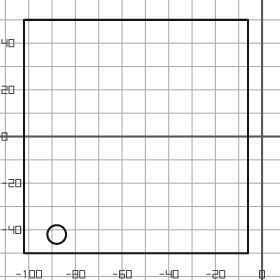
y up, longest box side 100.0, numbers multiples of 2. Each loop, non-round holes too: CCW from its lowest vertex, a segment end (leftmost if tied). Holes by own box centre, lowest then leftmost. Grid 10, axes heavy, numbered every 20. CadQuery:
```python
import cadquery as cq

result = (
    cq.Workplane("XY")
    .moveTo(-102.0, -50.0)
    .lineTo(-6.0, -50.0)
    .lineTo(-6.0, 50.0)
    .lineTo(-102.0, 50.0)
    .close()
    .moveTo(-88.0, -42.0)
    .circle(4.0)
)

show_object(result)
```